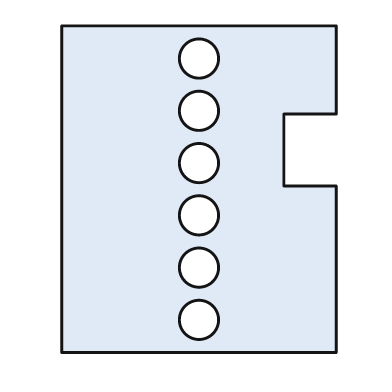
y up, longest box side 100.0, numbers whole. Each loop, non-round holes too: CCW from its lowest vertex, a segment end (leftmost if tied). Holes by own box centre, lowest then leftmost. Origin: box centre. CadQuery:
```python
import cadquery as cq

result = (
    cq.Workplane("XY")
    .moveTo(-42.0, -50.0)
    .lineTo(42.0, -50.0)
    .lineTo(42.0, 1.0)
    .lineTo(26.0, 1.0)
    .lineTo(26.0, 23.0)
    .lineTo(42.0, 23.0)
    .lineTo(42.0, 50.0)
    .lineTo(-42.0, 50.0)
    .close()
    .moveTo(0.0, -40.0)
    .circle(6.0)
    .moveTo(0.0, -24.0)
    .circle(6.0)
    .moveTo(0.0, -8.0)
    .circle(6.0)
    .moveTo(0.0, 8.0)
    .circle(6.0)
    .moveTo(0.0, 24.0)
    .circle(6.0)
    .moveTo(0.0, 40.0)
    .circle(6.0)
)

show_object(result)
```